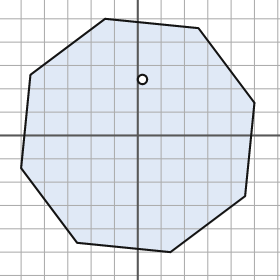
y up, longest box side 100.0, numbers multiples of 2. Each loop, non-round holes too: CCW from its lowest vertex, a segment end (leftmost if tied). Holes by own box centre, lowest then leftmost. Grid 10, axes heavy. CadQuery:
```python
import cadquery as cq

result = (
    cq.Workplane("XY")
    .moveTo(14.0, -50.0)
    .lineTo(46.0, -26.0)
    .lineTo(50.0, 14.0)
    .lineTo(26.0, 46.0)
    .lineTo(-14.0, 50.0)
    .lineTo(-46.0, 26.0)
    .lineTo(-50.0, -14.0)
    .lineTo(-26.0, -46.0)
    .close()
    .moveTo(2.0, 24.0)
    .circle(2.0)
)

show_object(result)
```